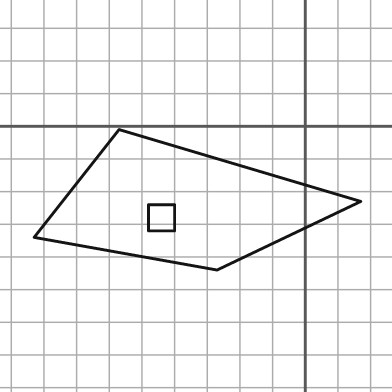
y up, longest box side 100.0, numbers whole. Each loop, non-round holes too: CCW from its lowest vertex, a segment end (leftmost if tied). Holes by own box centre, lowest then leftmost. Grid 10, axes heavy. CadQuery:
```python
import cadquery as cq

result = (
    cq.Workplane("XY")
    .moveTo(-27.0, -44.0)
    .lineTo(17.0, -23.0)
    .lineTo(-57.0, -1.0)
    .lineTo(-83.0, -34.0)
    .close()
    .moveTo(-48.0, -32.0)
    .lineTo(-40.0, -32.0)
    .lineTo(-40.0, -24.0)
    .lineTo(-48.0, -24.0)
    .close()
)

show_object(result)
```